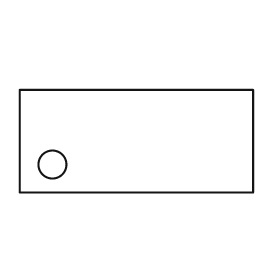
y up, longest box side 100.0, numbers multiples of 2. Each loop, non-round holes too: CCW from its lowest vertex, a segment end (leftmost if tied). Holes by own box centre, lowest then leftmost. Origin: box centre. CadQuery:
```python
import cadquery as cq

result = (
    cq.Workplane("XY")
    .moveTo(-50.0, -22.0)
    .lineTo(50.0, -22.0)
    .lineTo(50.0, 22.0)
    .lineTo(-50.0, 22.0)
    .close()
    .moveTo(-36.0, -10.0)
    .circle(6.0)
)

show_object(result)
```